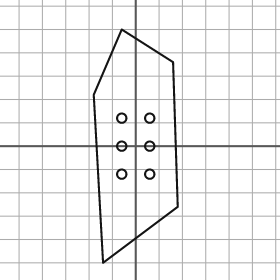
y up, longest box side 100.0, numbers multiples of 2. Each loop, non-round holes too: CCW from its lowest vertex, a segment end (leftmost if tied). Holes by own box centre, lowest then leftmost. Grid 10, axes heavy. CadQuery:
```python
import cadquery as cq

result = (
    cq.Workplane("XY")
    .moveTo(-14.0, -50.0)
    .lineTo(18.0, -26.0)
    .lineTo(16.0, 36.0)
    .lineTo(-6.0, 50.0)
    .lineTo(-18.0, 22.0)
    .close()
    .moveTo(-6.0, -12.0)
    .circle(2.0)
    .moveTo(6.0, -12.0)
    .circle(2.0)
    .moveTo(-6.0, 0.0)
    .circle(2.0)
    .moveTo(6.0, 0.0)
    .circle(2.0)
    .moveTo(-6.0, 12.0)
    .circle(2.0)
    .moveTo(6.0, 12.0)
    .circle(2.0)
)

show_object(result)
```